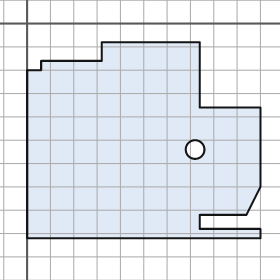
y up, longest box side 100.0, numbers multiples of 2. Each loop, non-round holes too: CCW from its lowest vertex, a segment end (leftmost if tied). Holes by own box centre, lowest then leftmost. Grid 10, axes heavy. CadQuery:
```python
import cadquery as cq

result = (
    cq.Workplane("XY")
    .moveTo(0.0, -92.0)
    .lineTo(100.0, -92.0)
    .lineTo(100.0, -88.0)
    .lineTo(74.0, -88.0)
    .lineTo(74.0, -82.0)
    .lineTo(94.0, -82.0)
    .lineTo(100.0, -70.0)
    .lineTo(100.0, -36.0)
    .lineTo(74.0, -36.0)
    .lineTo(74.0, -8.0)
    .lineTo(32.0, -8.0)
    .lineTo(32.0, -16.0)
    .lineTo(6.0, -16.0)
    .lineTo(6.0, -20.0)
    .lineTo(0.0, -20.0)
    .close()
    .moveTo(72.0, -54.0)
    .circle(4.0)
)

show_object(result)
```